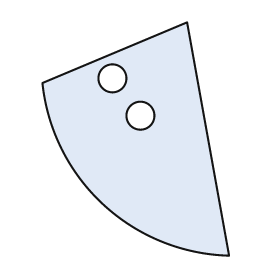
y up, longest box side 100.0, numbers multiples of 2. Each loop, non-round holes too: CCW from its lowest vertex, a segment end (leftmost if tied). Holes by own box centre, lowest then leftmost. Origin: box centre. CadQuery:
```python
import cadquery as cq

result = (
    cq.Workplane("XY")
    .moveTo(40.0, -50.0)
    .lineTo(22.0, 50.0)
    .lineTo(-40.0, 24.0)
    .threePointArc((-14.0, -28.0), (40.0, -50.0))
    .close()
    .moveTo(2.0, 10.0)
    .circle(6.0)
    .moveTo(-10.0, 26.0)
    .circle(6.0)
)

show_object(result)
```